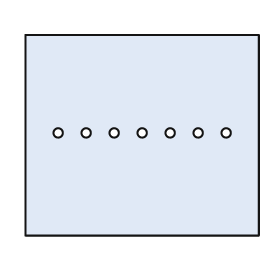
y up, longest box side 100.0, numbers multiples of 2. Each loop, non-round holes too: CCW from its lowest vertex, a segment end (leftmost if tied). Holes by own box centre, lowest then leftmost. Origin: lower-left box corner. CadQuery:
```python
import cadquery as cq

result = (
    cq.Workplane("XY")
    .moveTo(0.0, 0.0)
    .lineTo(100.0, 0.0)
    .lineTo(100.0, 86.0)
    .lineTo(0.0, 86.0)
    .close()
    .moveTo(14.0, 44.0)
    .circle(2.0)
    .moveTo(26.0, 44.0)
    .circle(2.0)
    .moveTo(38.0, 44.0)
    .circle(2.0)
    .moveTo(50.0, 44.0)
    .circle(2.0)
    .moveTo(62.0, 44.0)
    .circle(2.0)
    .moveTo(74.0, 44.0)
    .circle(2.0)
    .moveTo(86.0, 44.0)
    .circle(2.0)
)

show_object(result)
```